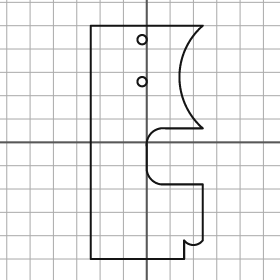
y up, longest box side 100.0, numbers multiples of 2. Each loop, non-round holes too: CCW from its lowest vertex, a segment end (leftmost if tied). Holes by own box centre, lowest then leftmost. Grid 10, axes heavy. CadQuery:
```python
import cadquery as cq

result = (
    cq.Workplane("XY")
    .moveTo(-24.0, -50.0)
    .lineTo(16.0, -50.0)
    .lineTo(16.0, -42.0)
    .threePointArc((20.0, -44.0), (24.0, -42.0))
    .lineTo(24.0, -18.0)
    .lineTo(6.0, -18.0)
    .threePointArc((2.0, -16.0), (0.0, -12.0))
    .lineTo(0.0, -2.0)
    .threePointArc((2.0, 4.0), (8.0, 6.0))
    .lineTo(24.0, 6.0)
    .threePointArc((14.0, 28.0), (24.0, 50.0))
    .lineTo(-24.0, 50.0)
    .close()
    .moveTo(-2.0, 26.0)
    .circle(2.0)
    .moveTo(-2.0, 44.0)
    .circle(2.0)
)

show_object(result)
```